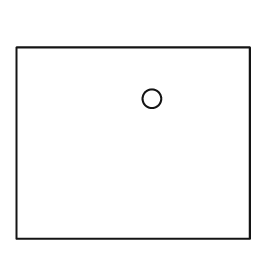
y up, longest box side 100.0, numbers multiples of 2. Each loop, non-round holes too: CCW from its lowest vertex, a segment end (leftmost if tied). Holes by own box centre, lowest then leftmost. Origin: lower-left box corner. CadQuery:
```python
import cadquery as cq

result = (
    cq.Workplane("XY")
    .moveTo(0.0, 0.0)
    .lineTo(100.0, 0.0)
    .lineTo(100.0, 82.0)
    .lineTo(0.0, 82.0)
    .close()
    .moveTo(58.0, 60.0)
    .circle(4.0)
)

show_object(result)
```